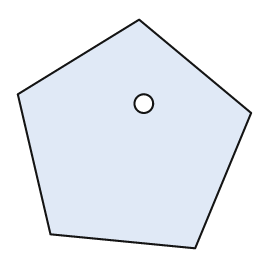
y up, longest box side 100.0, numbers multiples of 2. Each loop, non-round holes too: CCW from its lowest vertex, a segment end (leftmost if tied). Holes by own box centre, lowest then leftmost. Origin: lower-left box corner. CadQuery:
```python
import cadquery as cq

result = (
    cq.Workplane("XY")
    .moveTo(76.0, 0.0)
    .lineTo(100.0, 58.0)
    .lineTo(52.0, 98.0)
    .lineTo(0.0, 66.0)
    .lineTo(14.0, 6.0)
    .close()
    .moveTo(54.0, 62.0)
    .circle(4.0)
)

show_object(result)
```